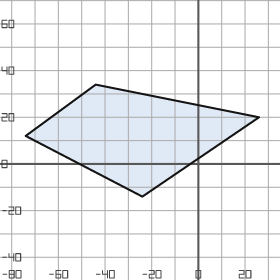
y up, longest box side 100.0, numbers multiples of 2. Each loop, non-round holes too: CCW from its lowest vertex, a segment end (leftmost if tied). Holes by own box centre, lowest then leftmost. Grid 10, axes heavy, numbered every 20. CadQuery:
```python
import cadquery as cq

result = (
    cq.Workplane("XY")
    .moveTo(-24.0, -14.0)
    .lineTo(26.0, 20.0)
    .lineTo(-44.0, 34.0)
    .lineTo(-74.0, 12.0)
    .close()
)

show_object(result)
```